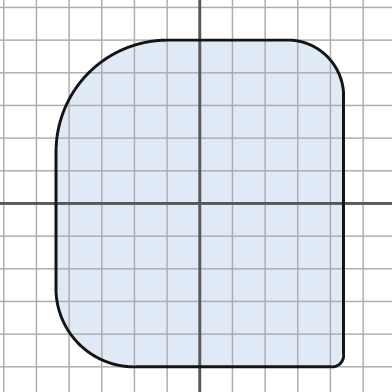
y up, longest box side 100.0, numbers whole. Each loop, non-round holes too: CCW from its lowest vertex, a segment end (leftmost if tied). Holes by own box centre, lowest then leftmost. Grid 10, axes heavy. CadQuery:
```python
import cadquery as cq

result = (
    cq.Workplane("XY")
    .moveTo(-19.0, -50.0)
    .lineTo(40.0, -50.0)
    .threePointArc((43.0, -49.0), (44.0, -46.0))
    .lineTo(44.0, 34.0)
    .threePointArc((39.0, 45.0), (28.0, 50.0))
    .lineTo(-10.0, 50.0)
    .threePointArc((-34.0, 40.0), (-44.0, 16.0))
    .lineTo(-44.0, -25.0)
    .threePointArc((-37.0, -43.0), (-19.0, -50.0))
    .close()
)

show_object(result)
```